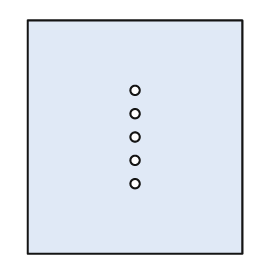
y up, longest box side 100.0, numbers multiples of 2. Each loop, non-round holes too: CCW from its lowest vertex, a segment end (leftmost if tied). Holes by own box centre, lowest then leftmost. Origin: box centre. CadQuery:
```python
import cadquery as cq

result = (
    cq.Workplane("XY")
    .moveTo(-46.0, -50.0)
    .lineTo(46.0, -50.0)
    .lineTo(46.0, 50.0)
    .lineTo(-46.0, 50.0)
    .close()
    .moveTo(0.0, -20.0)
    .circle(2.0)
    .moveTo(0.0, -10.0)
    .circle(2.0)
    .moveTo(0.0, 0.0)
    .circle(2.0)
    .moveTo(0.0, 10.0)
    .circle(2.0)
    .moveTo(0.0, 20.0)
    .circle(2.0)
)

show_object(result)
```